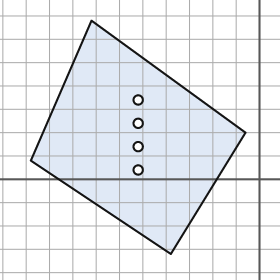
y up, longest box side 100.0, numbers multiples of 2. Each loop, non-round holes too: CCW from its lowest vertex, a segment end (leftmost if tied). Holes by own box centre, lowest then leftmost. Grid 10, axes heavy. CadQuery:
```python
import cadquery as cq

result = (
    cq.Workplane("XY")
    .moveTo(-38.0, -32.0)
    .lineTo(-6.0, 20.0)
    .lineTo(-72.0, 68.0)
    .lineTo(-98.0, 8.0)
    .close()
    .moveTo(-52.0, 4.0)
    .circle(2.0)
    .moveTo(-52.0, 14.0)
    .circle(2.0)
    .moveTo(-52.0, 24.0)
    .circle(2.0)
    .moveTo(-52.0, 34.0)
    .circle(2.0)
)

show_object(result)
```